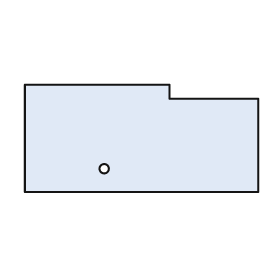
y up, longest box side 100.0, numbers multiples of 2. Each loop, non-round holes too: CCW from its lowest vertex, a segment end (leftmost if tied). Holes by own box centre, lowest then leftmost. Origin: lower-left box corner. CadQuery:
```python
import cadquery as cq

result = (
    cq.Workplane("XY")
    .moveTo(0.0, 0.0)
    .lineTo(100.0, 0.0)
    .lineTo(100.0, 40.0)
    .lineTo(62.0, 40.0)
    .lineTo(62.0, 46.0)
    .lineTo(0.0, 46.0)
    .close()
    .moveTo(34.0, 10.0)
    .circle(2.0)
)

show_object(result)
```